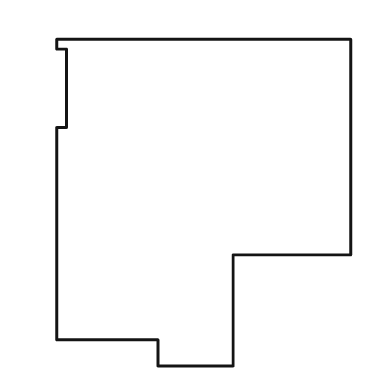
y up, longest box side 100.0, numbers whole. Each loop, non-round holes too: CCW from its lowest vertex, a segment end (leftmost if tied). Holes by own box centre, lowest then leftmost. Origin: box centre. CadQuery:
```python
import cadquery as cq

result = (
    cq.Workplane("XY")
    .moveTo(-14.0, -50.0)
    .lineTo(9.0, -50.0)
    .lineTo(9.0, -16.0)
    .lineTo(45.0, -16.0)
    .lineTo(45.0, 50.0)
    .lineTo(-45.0, 50.0)
    .lineTo(-45.0, 47.0)
    .lineTo(-42.0, 47.0)
    .lineTo(-42.0, 23.0)
    .lineTo(-45.0, 23.0)
    .lineTo(-45.0, -42.0)
    .lineTo(-14.0, -42.0)
    .close()
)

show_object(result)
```